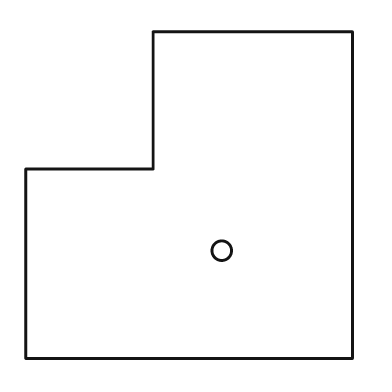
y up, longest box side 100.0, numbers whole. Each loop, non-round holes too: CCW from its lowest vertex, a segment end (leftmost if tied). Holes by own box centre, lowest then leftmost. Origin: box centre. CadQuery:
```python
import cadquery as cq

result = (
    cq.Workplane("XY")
    .moveTo(-50.0, -50.0)
    .lineTo(50.0, -50.0)
    .lineTo(50.0, 50.0)
    .lineTo(-11.0, 50.0)
    .lineTo(-11.0, 8.0)
    .lineTo(-50.0, 8.0)
    .close()
    .moveTo(10.0, -17.0)
    .circle(3.0)
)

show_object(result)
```